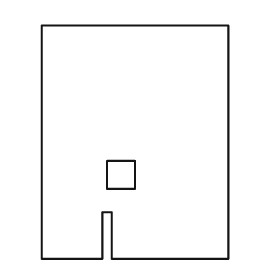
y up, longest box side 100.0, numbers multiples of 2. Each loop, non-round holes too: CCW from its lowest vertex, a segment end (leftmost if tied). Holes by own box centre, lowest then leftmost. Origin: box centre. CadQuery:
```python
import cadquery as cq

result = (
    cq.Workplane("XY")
    .moveTo(-40.0, -50.0)
    .lineTo(-14.0, -50.0)
    .lineTo(-14.0, -30.0)
    .lineTo(-10.0, -30.0)
    .lineTo(-10.0, -50.0)
    .lineTo(40.0, -50.0)
    .lineTo(40.0, 50.0)
    .lineTo(-40.0, 50.0)
    .close()
    .moveTo(-12.0, -20.0)
    .lineTo(0.0, -20.0)
    .lineTo(0.0, -8.0)
    .lineTo(-12.0, -8.0)
    .close()
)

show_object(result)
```